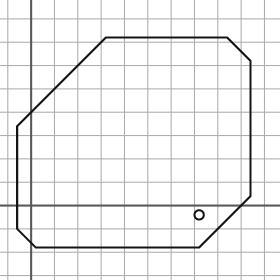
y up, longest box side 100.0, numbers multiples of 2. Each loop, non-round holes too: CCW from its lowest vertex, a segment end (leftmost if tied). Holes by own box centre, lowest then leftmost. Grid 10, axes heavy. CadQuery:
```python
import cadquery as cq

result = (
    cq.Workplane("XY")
    .moveTo(2.0, -18.0)
    .lineTo(72.0, -18.0)
    .lineTo(94.0, 4.0)
    .lineTo(94.0, 62.0)
    .lineTo(84.0, 72.0)
    .lineTo(32.0, 72.0)
    .lineTo(-6.0, 34.0)
    .lineTo(-6.0, -10.0)
    .close()
    .moveTo(72.0, -4.0)
    .circle(2.0)
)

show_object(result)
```